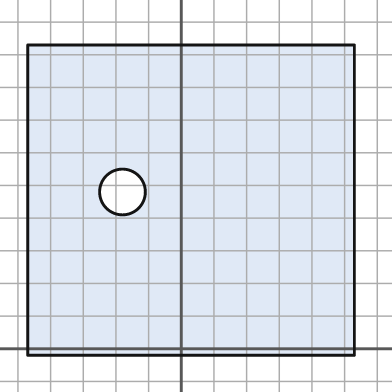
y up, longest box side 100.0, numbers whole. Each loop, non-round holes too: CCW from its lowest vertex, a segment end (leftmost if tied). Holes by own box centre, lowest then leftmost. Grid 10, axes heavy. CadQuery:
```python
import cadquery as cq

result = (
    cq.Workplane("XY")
    .moveTo(-47.0, -2.0)
    .lineTo(53.0, -2.0)
    .lineTo(53.0, 93.0)
    .lineTo(-47.0, 93.0)
    .close()
    .moveTo(-18.0, 48.0)
    .circle(7.0)
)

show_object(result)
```